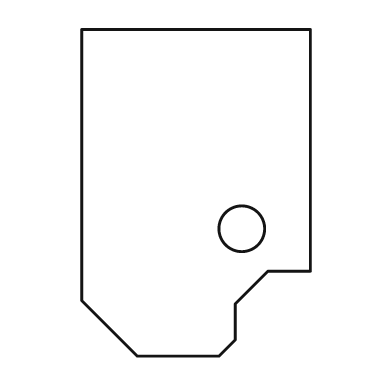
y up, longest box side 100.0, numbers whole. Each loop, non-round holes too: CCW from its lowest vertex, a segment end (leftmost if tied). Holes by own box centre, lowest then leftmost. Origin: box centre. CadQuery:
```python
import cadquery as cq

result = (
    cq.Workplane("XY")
    .moveTo(-18.0, -50.0)
    .lineTo(7.0, -50.0)
    .lineTo(12.0, -45.0)
    .lineTo(12.0, -34.0)
    .lineTo(22.0, -24.0)
    .lineTo(35.0, -24.0)
    .lineTo(35.0, 50.0)
    .lineTo(-35.0, 50.0)
    .lineTo(-35.0, -33.0)
    .close()
    .moveTo(14.0, -11.0)
    .circle(7.0)
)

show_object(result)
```